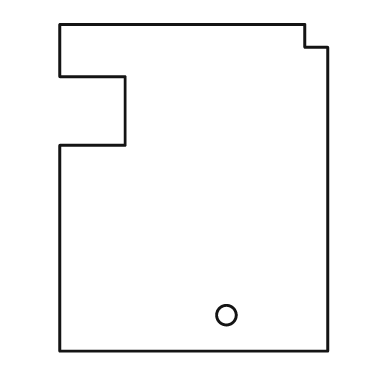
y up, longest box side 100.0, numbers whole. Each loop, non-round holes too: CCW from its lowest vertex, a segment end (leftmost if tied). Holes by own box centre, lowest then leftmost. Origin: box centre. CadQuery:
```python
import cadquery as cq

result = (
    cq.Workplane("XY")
    .moveTo(-41.0, -50.0)
    .lineTo(41.0, -50.0)
    .lineTo(41.0, 43.0)
    .lineTo(34.0, 43.0)
    .lineTo(34.0, 50.0)
    .lineTo(-41.0, 50.0)
    .lineTo(-41.0, 34.0)
    .lineTo(-21.0, 34.0)
    .lineTo(-21.0, 13.0)
    .lineTo(-41.0, 13.0)
    .close()
    .moveTo(10.0, -39.0)
    .circle(3.0)
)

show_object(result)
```